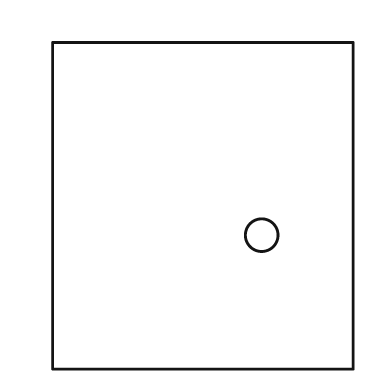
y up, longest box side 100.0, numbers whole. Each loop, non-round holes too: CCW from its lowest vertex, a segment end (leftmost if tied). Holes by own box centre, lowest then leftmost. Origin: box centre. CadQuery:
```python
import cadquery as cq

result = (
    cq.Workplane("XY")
    .moveTo(-46.0, -50.0)
    .lineTo(46.0, -50.0)
    .lineTo(46.0, 50.0)
    .lineTo(-46.0, 50.0)
    .close()
    .moveTo(18.0, -9.0)
    .circle(5.0)
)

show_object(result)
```